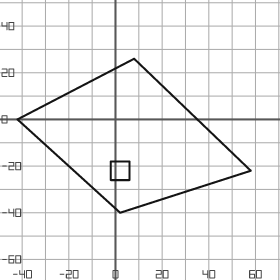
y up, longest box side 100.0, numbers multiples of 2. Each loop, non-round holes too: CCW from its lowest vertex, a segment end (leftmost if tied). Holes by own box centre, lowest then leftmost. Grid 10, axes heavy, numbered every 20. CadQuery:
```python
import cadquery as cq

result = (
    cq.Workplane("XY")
    .moveTo(2.0, -40.0)
    .lineTo(58.0, -22.0)
    .lineTo(8.0, 26.0)
    .lineTo(-42.0, 0.0)
    .close()
    .moveTo(-2.0, -26.0)
    .lineTo(6.0, -26.0)
    .lineTo(6.0, -18.0)
    .lineTo(-2.0, -18.0)
    .close()
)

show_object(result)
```